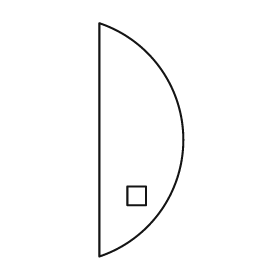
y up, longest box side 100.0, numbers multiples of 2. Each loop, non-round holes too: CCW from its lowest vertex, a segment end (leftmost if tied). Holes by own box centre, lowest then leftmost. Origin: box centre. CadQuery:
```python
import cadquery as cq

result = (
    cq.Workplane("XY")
    .moveTo(-18.0, -50.0)
    .threePointArc((18.0, 0.0), (-18.0, 50.0))
    .close()
    .moveTo(-6.0, -28.0)
    .lineTo(2.0, -28.0)
    .lineTo(2.0, -20.0)
    .lineTo(-6.0, -20.0)
    .close()
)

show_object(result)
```